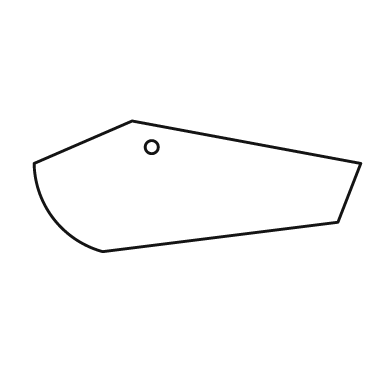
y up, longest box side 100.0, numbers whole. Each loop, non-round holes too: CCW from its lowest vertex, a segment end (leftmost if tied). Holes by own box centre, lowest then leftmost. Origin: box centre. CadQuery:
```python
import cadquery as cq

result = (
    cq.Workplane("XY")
    .moveTo(-29.0, -20.0)
    .lineTo(43.0, -11.0)
    .lineTo(50.0, 7.0)
    .lineTo(-20.0, 20.0)
    .lineTo(-50.0, 7.0)
    .threePointArc((-44.0, -10.0), (-29.0, -20.0))
    .close()
    .moveTo(-14.0, 12.0)
    .circle(2.0)
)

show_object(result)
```